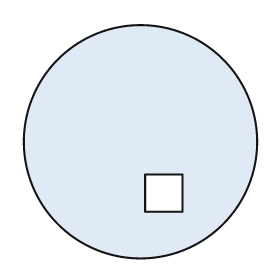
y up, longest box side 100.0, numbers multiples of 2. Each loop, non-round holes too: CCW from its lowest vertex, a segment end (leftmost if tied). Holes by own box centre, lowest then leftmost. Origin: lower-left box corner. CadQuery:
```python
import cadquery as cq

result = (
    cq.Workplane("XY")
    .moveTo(50.0, 50.0)
    .circle(50.0)
    .moveTo(52.0, 20.0)
    .lineTo(68.0, 20.0)
    .lineTo(68.0, 36.0)
    .lineTo(52.0, 36.0)
    .close()
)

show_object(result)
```